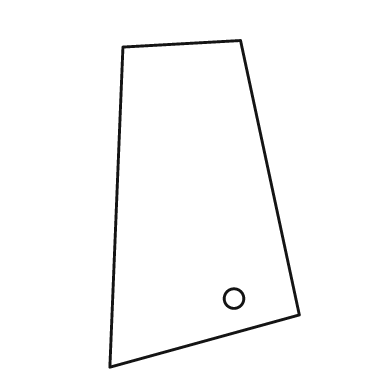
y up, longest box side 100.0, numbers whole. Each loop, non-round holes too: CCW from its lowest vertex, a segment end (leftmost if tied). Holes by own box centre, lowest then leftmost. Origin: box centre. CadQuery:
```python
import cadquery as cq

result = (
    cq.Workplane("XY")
    .moveTo(-29.0, -50.0)
    .lineTo(29.0, -34.0)
    .lineTo(11.0, 50.0)
    .lineTo(-25.0, 48.0)
    .close()
    .moveTo(9.0, -29.0)
    .circle(3.0)
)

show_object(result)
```